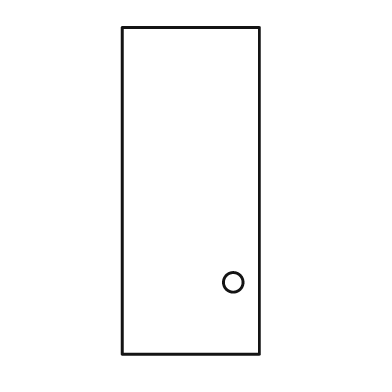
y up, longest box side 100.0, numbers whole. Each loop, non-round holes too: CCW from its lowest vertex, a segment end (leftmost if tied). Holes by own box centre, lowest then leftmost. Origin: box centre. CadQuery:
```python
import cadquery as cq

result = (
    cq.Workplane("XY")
    .moveTo(-21.0, -50.0)
    .lineTo(21.0, -50.0)
    .lineTo(21.0, 50.0)
    .lineTo(-21.0, 50.0)
    .close()
    .moveTo(13.0, -28.0)
    .circle(3.0)
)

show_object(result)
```